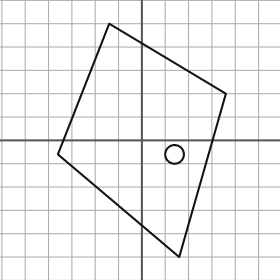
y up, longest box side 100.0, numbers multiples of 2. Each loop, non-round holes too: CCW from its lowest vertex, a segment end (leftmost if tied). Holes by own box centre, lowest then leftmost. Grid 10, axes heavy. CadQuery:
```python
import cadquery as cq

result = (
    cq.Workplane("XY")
    .moveTo(16.0, -50.0)
    .lineTo(36.0, 20.0)
    .lineTo(-14.0, 50.0)
    .lineTo(-36.0, -6.0)
    .close()
    .moveTo(14.0, -6.0)
    .circle(4.0)
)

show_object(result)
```